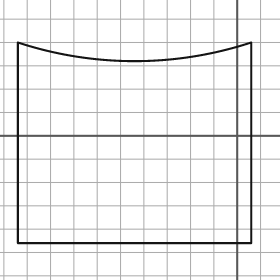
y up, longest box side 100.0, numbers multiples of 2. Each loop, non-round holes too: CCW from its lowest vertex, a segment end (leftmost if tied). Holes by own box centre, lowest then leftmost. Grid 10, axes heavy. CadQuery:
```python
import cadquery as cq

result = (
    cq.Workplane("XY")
    .moveTo(-94.0, -46.0)
    .lineTo(6.0, -46.0)
    .lineTo(6.0, 40.0)
    .threePointArc((-44.0, 32.0), (-94.0, 40.0))
    .close()
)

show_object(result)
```